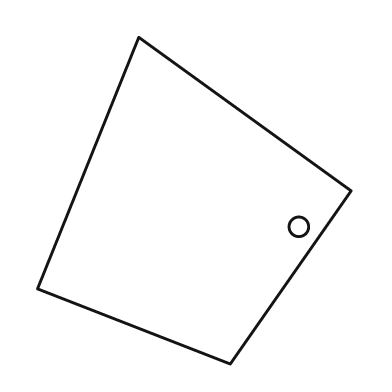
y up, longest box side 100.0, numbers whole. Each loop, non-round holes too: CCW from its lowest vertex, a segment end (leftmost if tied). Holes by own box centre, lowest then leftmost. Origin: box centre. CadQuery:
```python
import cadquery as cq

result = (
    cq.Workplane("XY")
    .moveTo(11.0, -50.0)
    .lineTo(48.0, 3.0)
    .lineTo(-17.0, 50.0)
    .lineTo(-48.0, -27.0)
    .close()
    .moveTo(32.0, -8.0)
    .circle(3.0)
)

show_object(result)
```